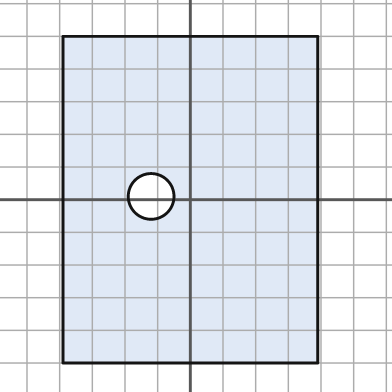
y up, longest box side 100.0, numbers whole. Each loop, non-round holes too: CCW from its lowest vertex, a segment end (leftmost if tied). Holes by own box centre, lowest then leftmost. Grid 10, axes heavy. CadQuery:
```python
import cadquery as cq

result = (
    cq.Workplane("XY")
    .moveTo(-39.0, -50.0)
    .lineTo(39.0, -50.0)
    .lineTo(39.0, 50.0)
    .lineTo(-39.0, 50.0)
    .close()
    .moveTo(-12.0, 1.0)
    .circle(7.0)
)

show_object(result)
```